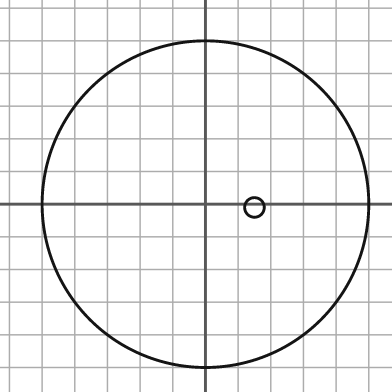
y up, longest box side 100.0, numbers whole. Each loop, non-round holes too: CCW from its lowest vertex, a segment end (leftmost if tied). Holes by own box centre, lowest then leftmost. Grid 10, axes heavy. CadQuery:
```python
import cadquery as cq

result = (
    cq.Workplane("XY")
    .moveTo(0.0, 0.0)
    .circle(50.0)
    .moveTo(15.0, -1.0)
    .circle(3.0)
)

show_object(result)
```